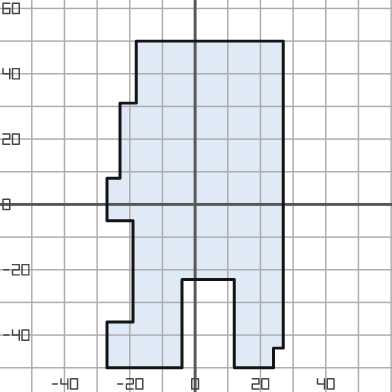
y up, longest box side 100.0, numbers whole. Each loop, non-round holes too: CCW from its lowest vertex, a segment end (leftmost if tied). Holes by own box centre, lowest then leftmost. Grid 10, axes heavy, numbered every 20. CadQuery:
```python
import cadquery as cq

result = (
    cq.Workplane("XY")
    .moveTo(-27.0, -50.0)
    .lineTo(-4.0, -50.0)
    .lineTo(-4.0, -23.0)
    .lineTo(12.0, -23.0)
    .lineTo(12.0, -50.0)
    .lineTo(24.0, -50.0)
    .lineTo(24.0, -44.0)
    .lineTo(27.0, -44.0)
    .lineTo(27.0, 50.0)
    .lineTo(-18.0, 50.0)
    .lineTo(-18.0, 31.0)
    .lineTo(-23.0, 31.0)
    .lineTo(-23.0, 8.0)
    .lineTo(-27.0, 8.0)
    .lineTo(-27.0, -5.0)
    .lineTo(-19.0, -5.0)
    .lineTo(-19.0, -36.0)
    .lineTo(-27.0, -36.0)
    .close()
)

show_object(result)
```